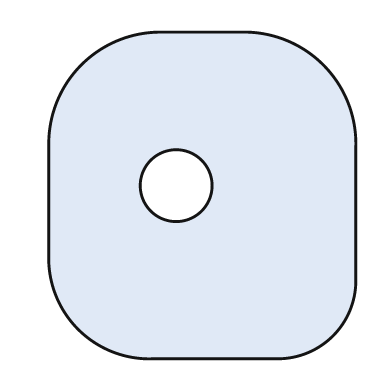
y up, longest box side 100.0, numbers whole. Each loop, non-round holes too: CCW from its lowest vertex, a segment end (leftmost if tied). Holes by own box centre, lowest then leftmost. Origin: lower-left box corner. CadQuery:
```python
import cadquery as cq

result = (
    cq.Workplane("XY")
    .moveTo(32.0, 0.0)
    .lineTo(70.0, 0.0)
    .threePointArc((87.0, 7.0), (94.0, 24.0))
    .lineTo(94.0, 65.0)
    .threePointArc((84.0, 90.0), (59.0, 100.0))
    .lineTo(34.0, 100.0)
    .threePointArc((10.0, 90.0), (0.0, 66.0))
    .lineTo(0.0, 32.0)
    .threePointArc((9.0, 9.0), (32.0, 0.0))
    .close()
    .moveTo(39.0, 53.0)
    .circle(11.0)
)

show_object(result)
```